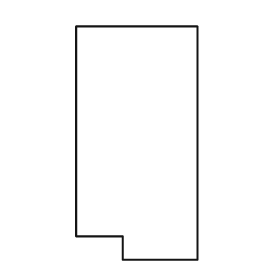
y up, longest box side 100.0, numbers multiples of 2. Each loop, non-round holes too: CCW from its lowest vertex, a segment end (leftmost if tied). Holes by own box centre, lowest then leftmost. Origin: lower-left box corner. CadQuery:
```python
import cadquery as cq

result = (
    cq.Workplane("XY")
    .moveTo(20.0, 0.0)
    .lineTo(52.0, 0.0)
    .lineTo(52.0, 100.0)
    .lineTo(0.0, 100.0)
    .lineTo(0.0, 10.0)
    .lineTo(20.0, 10.0)
    .close()
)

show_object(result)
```